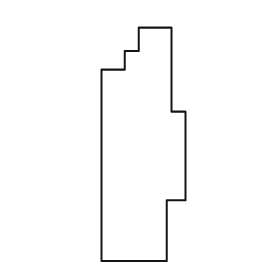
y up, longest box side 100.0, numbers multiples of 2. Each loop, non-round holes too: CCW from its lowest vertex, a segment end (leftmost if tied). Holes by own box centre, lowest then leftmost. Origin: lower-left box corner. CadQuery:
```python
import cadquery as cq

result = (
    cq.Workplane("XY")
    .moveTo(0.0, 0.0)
    .lineTo(28.0, 0.0)
    .lineTo(28.0, 26.0)
    .lineTo(36.0, 26.0)
    .lineTo(36.0, 64.0)
    .lineTo(30.0, 64.0)
    .lineTo(30.0, 100.0)
    .lineTo(16.0, 100.0)
    .lineTo(16.0, 90.0)
    .lineTo(10.0, 90.0)
    .lineTo(10.0, 82.0)
    .lineTo(0.0, 82.0)
    .close()
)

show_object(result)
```